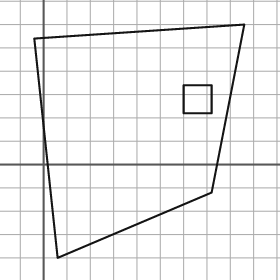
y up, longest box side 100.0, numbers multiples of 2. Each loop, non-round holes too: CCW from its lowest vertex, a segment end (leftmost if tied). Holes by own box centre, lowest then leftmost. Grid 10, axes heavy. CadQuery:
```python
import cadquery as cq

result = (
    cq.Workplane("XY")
    .moveTo(6.0, -40.0)
    .lineTo(72.0, -12.0)
    .lineTo(86.0, 60.0)
    .lineTo(-4.0, 54.0)
    .close()
    .moveTo(60.0, 22.0)
    .lineTo(72.0, 22.0)
    .lineTo(72.0, 34.0)
    .lineTo(60.0, 34.0)
    .close()
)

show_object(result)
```